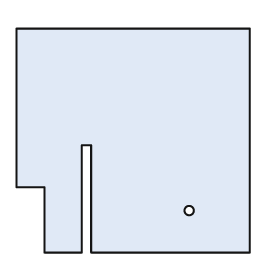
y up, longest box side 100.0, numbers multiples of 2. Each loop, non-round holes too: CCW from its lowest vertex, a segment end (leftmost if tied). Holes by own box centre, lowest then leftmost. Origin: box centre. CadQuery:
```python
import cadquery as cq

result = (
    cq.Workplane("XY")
    .moveTo(-38.0, -48.0)
    .lineTo(-22.0, -48.0)
    .lineTo(-22.0, -2.0)
    .lineTo(-18.0, -2.0)
    .lineTo(-18.0, -48.0)
    .lineTo(50.0, -48.0)
    .lineTo(50.0, 48.0)
    .lineTo(-50.0, 48.0)
    .lineTo(-50.0, -20.0)
    .lineTo(-38.0, -20.0)
    .close()
    .moveTo(24.0, -30.0)
    .circle(2.0)
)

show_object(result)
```